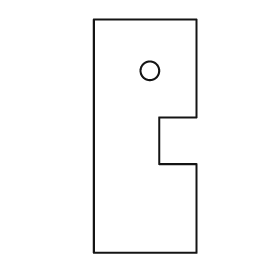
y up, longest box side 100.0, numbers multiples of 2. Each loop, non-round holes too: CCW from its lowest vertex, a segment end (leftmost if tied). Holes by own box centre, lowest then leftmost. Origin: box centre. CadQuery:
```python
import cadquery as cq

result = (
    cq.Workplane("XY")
    .moveTo(-22.0, -50.0)
    .lineTo(22.0, -50.0)
    .lineTo(22.0, -12.0)
    .lineTo(6.0, -12.0)
    .lineTo(6.0, 8.0)
    .lineTo(22.0, 8.0)
    .lineTo(22.0, 50.0)
    .lineTo(-22.0, 50.0)
    .close()
    .moveTo(2.0, 28.0)
    .circle(4.0)
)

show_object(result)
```